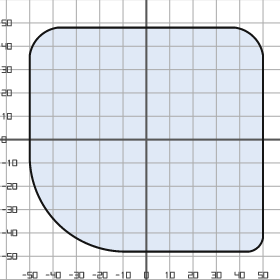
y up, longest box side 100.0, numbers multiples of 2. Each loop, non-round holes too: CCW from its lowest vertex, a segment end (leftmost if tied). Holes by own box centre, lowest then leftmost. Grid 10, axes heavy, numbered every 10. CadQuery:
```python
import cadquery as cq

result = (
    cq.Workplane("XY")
    .moveTo(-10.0, -48.0)
    .lineTo(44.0, -48.0)
    .threePointArc((48.0, -46.0), (50.0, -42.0))
    .lineTo(50.0, 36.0)
    .threePointArc((46.0, 44.0), (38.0, 48.0))
    .lineTo(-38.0, 48.0)
    .threePointArc((-46.0, 44.0), (-50.0, 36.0))
    .lineTo(-50.0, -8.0)
    .threePointArc((-38.0, -36.0), (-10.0, -48.0))
    .close()
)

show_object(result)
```